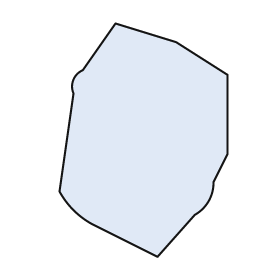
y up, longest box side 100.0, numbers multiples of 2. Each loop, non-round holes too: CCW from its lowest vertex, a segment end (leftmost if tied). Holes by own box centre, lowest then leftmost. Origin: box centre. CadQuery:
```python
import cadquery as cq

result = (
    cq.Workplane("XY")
    .moveTo(6.0, -50.0)
    .lineTo(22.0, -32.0)
    .threePointArc((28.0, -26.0), (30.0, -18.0))
    .lineTo(36.0, -6.0)
    .lineTo(36.0, 28.0)
    .lineTo(14.0, 42.0)
    .lineTo(-12.0, 50.0)
    .lineTo(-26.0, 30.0)
    .threePointArc((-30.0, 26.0), (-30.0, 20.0))
    .lineTo(-36.0, -22.0)
    .threePointArc((-30.0, -30.0), (-22.0, -36.0))
    .close()
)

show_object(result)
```